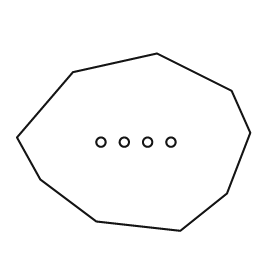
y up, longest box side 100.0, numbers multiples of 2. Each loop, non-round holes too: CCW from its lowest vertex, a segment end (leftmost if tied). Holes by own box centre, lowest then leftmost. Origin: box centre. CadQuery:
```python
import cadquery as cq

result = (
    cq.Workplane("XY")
    .moveTo(20.0, -38.0)
    .lineTo(40.0, -22.0)
    .lineTo(50.0, 4.0)
    .lineTo(42.0, 22.0)
    .lineTo(10.0, 38.0)
    .lineTo(-26.0, 30.0)
    .lineTo(-50.0, 2.0)
    .lineTo(-40.0, -16.0)
    .lineTo(-16.0, -34.0)
    .close()
    .moveTo(-14.0, 0.0)
    .circle(2.0)
    .moveTo(-4.0, 0.0)
    .circle(2.0)
    .moveTo(6.0, 0.0)
    .circle(2.0)
    .moveTo(16.0, 0.0)
    .circle(2.0)
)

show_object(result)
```